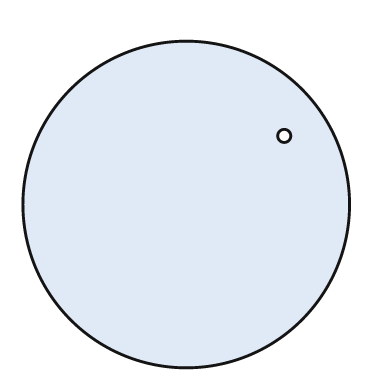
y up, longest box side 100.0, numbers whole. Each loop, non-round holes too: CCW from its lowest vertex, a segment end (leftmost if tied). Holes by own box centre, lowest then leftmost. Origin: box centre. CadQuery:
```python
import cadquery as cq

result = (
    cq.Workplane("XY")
    .moveTo(0.0, 0.0)
    .circle(50.0)
    .moveTo(30.0, 21.0)
    .circle(2.0)
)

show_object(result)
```